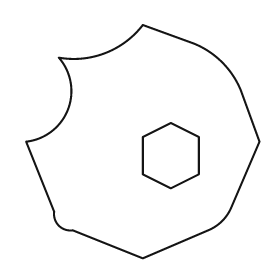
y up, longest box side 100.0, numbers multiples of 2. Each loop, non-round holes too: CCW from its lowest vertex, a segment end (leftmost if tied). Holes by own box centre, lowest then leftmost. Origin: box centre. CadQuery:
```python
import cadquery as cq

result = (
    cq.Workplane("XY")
    .moveTo(0.0, -50.0)
    .lineTo(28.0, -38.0)
    .threePointArc((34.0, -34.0), (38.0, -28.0))
    .lineTo(50.0, 0.0)
    .lineTo(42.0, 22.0)
    .threePointArc((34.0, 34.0), (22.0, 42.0))
    .lineTo(0.0, 50.0)
    .threePointArc((-16.0, 38.0), (-36.0, 36.0))
    .threePointArc((-32.0, 14.0), (-50.0, 0.0))
    .lineTo(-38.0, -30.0)
    .threePointArc((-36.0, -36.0), (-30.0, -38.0))
    .close()
    .moveTo(12.0, -20.0)
    .lineTo(24.0, -14.0)
    .lineTo(24.0, 2.0)
    .lineTo(12.0, 8.0)
    .lineTo(0.0, 2.0)
    .lineTo(0.0, -14.0)
    .close()
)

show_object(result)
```